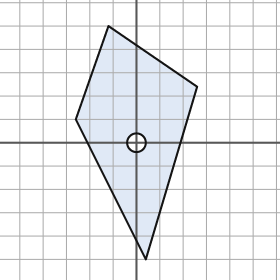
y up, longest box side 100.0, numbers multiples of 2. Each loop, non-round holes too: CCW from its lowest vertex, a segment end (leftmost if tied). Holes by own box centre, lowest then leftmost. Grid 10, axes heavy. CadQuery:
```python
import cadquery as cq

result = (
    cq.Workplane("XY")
    .moveTo(4.0, -50.0)
    .lineTo(26.0, 24.0)
    .lineTo(-12.0, 50.0)
    .lineTo(-26.0, 10.0)
    .close()
    .moveTo(0.0, 0.0)
    .circle(4.0)
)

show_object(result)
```